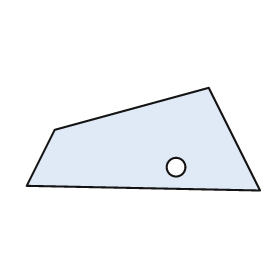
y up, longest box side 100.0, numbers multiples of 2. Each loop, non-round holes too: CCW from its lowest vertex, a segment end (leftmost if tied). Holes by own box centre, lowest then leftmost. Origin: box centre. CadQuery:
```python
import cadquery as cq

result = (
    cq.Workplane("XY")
    .moveTo(50.0, -22.0)
    .lineTo(28.0, 22.0)
    .lineTo(-38.0, 4.0)
    .lineTo(-50.0, -20.0)
    .close()
    .moveTo(14.0, -12.0)
    .circle(4.0)
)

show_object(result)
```